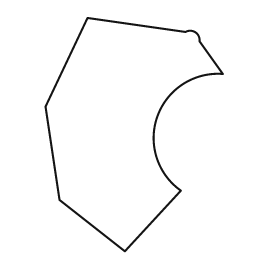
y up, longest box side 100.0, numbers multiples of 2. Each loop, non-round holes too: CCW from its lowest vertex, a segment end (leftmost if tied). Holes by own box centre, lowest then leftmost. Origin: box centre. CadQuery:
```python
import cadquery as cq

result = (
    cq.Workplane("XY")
    .moveTo(-4.0, -50.0)
    .lineTo(20.0, -24.0)
    .threePointArc((10.0, 8.0), (38.0, 26.0))
    .lineTo(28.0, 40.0)
    .threePointArc((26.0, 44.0), (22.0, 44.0))
    .lineTo(-20.0, 50.0)
    .lineTo(-38.0, 12.0)
    .lineTo(-32.0, -28.0)
    .close()
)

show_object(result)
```